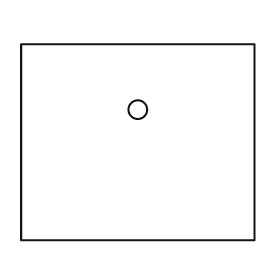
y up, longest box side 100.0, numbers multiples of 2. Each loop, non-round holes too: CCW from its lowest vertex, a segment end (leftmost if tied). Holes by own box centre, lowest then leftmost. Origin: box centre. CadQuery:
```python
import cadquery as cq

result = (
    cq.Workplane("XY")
    .moveTo(-50.0, -42.0)
    .lineTo(50.0, -42.0)
    .lineTo(50.0, 42.0)
    .lineTo(-50.0, 42.0)
    .close()
    .moveTo(0.0, 14.0)
    .circle(4.0)
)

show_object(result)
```